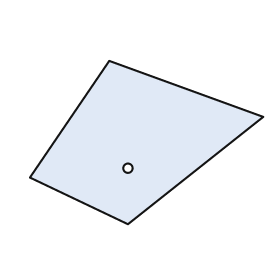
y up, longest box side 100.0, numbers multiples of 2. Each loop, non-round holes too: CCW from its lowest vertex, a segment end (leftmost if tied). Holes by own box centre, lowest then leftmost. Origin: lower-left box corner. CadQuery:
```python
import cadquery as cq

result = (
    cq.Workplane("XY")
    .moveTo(42.0, 0.0)
    .lineTo(100.0, 46.0)
    .lineTo(34.0, 70.0)
    .lineTo(0.0, 20.0)
    .close()
    .moveTo(42.0, 24.0)
    .circle(2.0)
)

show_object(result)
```